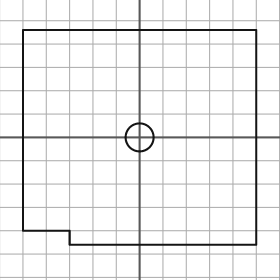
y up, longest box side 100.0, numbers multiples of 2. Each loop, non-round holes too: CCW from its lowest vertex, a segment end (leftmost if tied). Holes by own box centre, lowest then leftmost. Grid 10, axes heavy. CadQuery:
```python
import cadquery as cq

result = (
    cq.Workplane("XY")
    .moveTo(-30.0, -46.0)
    .lineTo(50.0, -46.0)
    .lineTo(50.0, 46.0)
    .lineTo(-50.0, 46.0)
    .lineTo(-50.0, -40.0)
    .lineTo(-30.0, -40.0)
    .close()
    .moveTo(0.0, 0.0)
    .circle(6.0)
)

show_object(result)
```